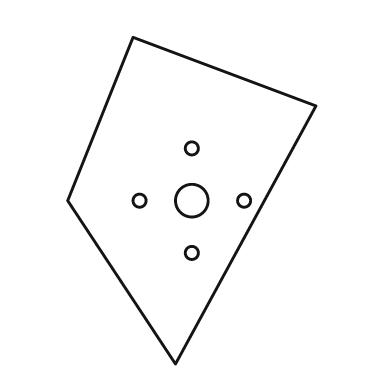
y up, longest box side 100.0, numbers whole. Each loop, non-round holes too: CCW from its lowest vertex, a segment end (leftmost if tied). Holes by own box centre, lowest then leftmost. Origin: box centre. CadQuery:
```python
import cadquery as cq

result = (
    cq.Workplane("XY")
    .moveTo(-5.0, -50.0)
    .lineTo(38.0, 29.0)
    .lineTo(-18.0, 50.0)
    .lineTo(-38.0, 0.0)
    .close()
    .moveTo(0.0, -16.0)
    .circle(2.0)
    .moveTo(-16.0, 0.0)
    .circle(2.0)
    .moveTo(0.0, 0.0)
    .circle(5.0)
    .moveTo(16.0, 0.0)
    .circle(2.0)
    .moveTo(0.0, 16.0)
    .circle(2.0)
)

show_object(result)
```